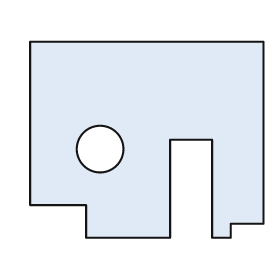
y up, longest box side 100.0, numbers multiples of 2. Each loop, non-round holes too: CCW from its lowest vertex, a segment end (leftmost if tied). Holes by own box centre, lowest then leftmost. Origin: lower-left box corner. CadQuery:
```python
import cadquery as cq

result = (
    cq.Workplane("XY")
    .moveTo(24.0, 0.0)
    .lineTo(60.0, 0.0)
    .lineTo(60.0, 42.0)
    .lineTo(78.0, 42.0)
    .lineTo(78.0, 0.0)
    .lineTo(86.0, 0.0)
    .lineTo(86.0, 6.0)
    .lineTo(100.0, 6.0)
    .lineTo(100.0, 84.0)
    .lineTo(0.0, 84.0)
    .lineTo(0.0, 14.0)
    .lineTo(24.0, 14.0)
    .close()
    .moveTo(30.0, 38.0)
    .circle(10.0)
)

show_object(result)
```